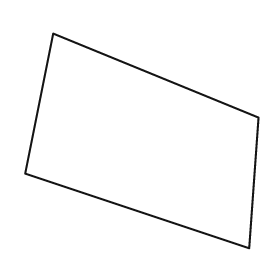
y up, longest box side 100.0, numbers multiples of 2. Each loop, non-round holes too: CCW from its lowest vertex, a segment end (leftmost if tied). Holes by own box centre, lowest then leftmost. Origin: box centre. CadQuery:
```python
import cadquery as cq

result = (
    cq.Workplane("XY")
    .moveTo(46.0, -46.0)
    .lineTo(50.0, 10.0)
    .lineTo(-38.0, 46.0)
    .lineTo(-50.0, -14.0)
    .close()
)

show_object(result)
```